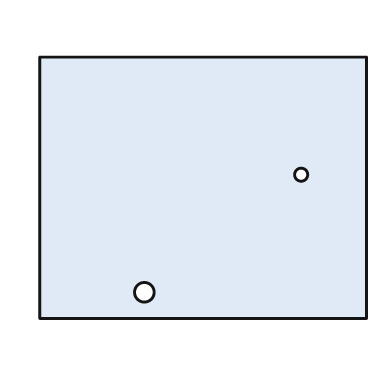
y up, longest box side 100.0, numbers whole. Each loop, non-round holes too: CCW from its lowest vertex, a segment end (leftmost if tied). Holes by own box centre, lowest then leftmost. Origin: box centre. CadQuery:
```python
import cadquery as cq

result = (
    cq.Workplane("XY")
    .moveTo(-50.0, -40.0)
    .lineTo(50.0, -40.0)
    .lineTo(50.0, 40.0)
    .lineTo(-50.0, 40.0)
    .close()
    .moveTo(-18.0, -32.0)
    .circle(3.0)
    .moveTo(30.0, 4.0)
    .circle(2.0)
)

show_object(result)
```